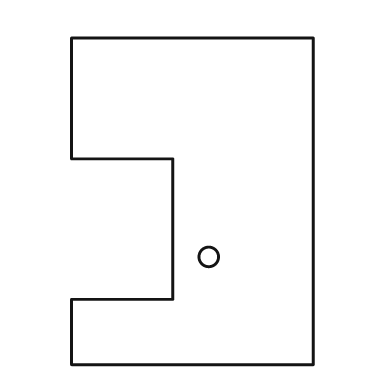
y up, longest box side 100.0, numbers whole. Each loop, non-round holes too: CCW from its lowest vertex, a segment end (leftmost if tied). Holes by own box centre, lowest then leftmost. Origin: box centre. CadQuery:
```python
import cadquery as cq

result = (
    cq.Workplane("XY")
    .moveTo(-37.0, -50.0)
    .lineTo(37.0, -50.0)
    .lineTo(37.0, 50.0)
    .lineTo(-37.0, 50.0)
    .lineTo(-37.0, 13.0)
    .lineTo(-6.0, 13.0)
    .lineTo(-6.0, -30.0)
    .lineTo(-37.0, -30.0)
    .close()
    .moveTo(5.0, -17.0)
    .circle(3.0)
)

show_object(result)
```